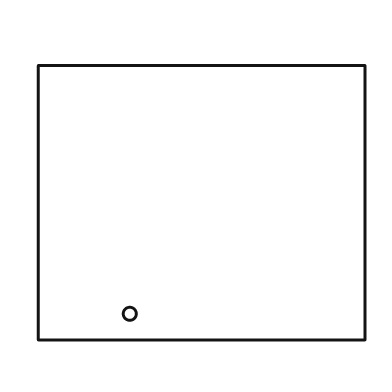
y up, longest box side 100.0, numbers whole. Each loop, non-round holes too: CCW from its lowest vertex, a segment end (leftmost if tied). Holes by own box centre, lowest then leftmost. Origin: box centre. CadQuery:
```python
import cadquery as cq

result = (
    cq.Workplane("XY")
    .moveTo(-50.0, -42.0)
    .lineTo(50.0, -42.0)
    .lineTo(50.0, 42.0)
    .lineTo(-50.0, 42.0)
    .close()
    .moveTo(-22.0, -34.0)
    .circle(2.0)
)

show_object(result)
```